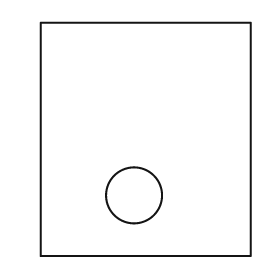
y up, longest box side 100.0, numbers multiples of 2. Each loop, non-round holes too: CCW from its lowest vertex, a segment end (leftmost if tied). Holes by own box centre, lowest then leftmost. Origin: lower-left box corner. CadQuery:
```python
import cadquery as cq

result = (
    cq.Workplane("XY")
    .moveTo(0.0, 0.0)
    .lineTo(90.0, 0.0)
    .lineTo(90.0, 100.0)
    .lineTo(0.0, 100.0)
    .close()
    .moveTo(40.0, 26.0)
    .circle(12.0)
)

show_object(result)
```